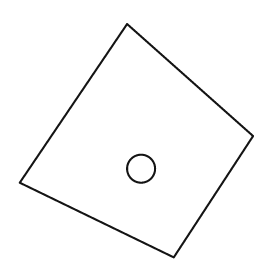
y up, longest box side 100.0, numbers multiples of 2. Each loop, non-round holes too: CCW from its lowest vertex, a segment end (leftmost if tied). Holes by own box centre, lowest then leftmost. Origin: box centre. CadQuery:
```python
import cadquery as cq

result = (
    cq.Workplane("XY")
    .moveTo(16.0, -50.0)
    .lineTo(50.0, 2.0)
    .lineTo(-4.0, 50.0)
    .lineTo(-50.0, -18.0)
    .close()
    .moveTo(2.0, -12.0)
    .circle(6.0)
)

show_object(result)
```